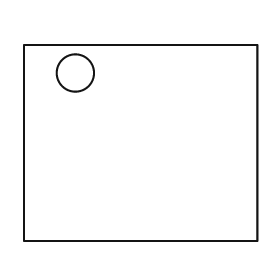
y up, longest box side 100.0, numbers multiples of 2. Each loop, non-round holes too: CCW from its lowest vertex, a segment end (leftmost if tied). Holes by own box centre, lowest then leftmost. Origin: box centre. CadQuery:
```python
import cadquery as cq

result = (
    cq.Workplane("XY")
    .moveTo(-50.0, -42.0)
    .lineTo(50.0, -42.0)
    .lineTo(50.0, 42.0)
    .lineTo(-50.0, 42.0)
    .close()
    .moveTo(-28.0, 30.0)
    .circle(8.0)
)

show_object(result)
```